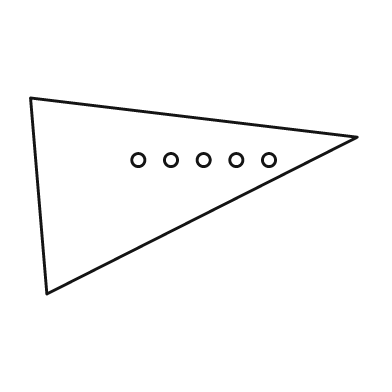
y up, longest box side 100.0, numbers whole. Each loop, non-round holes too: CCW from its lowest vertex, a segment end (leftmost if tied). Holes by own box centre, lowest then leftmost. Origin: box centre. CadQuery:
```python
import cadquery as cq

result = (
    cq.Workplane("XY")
    .moveTo(-45.0, -30.0)
    .lineTo(50.0, 18.0)
    .lineTo(-50.0, 30.0)
    .close()
    .moveTo(-17.0, 11.0)
    .circle(2.0)
    .moveTo(-7.0, 11.0)
    .circle(2.0)
    .moveTo(3.0, 11.0)
    .circle(2.0)
    .moveTo(13.0, 11.0)
    .circle(2.0)
    .moveTo(23.0, 11.0)
    .circle(2.0)
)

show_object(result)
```